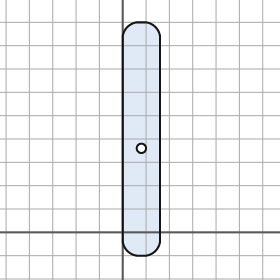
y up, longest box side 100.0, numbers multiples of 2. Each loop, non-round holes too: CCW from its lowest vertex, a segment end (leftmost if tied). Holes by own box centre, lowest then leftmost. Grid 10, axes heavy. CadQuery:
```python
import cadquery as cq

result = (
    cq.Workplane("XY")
    .moveTo(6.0, -10.0)
    .lineTo(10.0, -10.0)
    .threePointArc((14.0, -8.0), (16.0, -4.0))
    .lineTo(16.0, 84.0)
    .threePointArc((14.0, 88.0), (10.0, 90.0))
    .lineTo(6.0, 90.0)
    .threePointArc((2.0, 88.0), (0.0, 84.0))
    .lineTo(0.0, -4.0)
    .threePointArc((2.0, -8.0), (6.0, -10.0))
    .close()
    .moveTo(8.0, 36.0)
    .circle(2.0)
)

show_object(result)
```